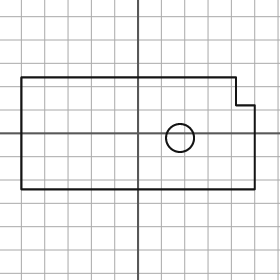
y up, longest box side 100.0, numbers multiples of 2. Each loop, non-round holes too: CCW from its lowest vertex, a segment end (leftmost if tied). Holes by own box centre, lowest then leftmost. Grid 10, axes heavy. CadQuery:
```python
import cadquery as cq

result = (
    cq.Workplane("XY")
    .moveTo(-50.0, -24.0)
    .lineTo(50.0, -24.0)
    .lineTo(50.0, 12.0)
    .lineTo(42.0, 12.0)
    .lineTo(42.0, 24.0)
    .lineTo(-50.0, 24.0)
    .close()
    .moveTo(18.0, -2.0)
    .circle(6.0)
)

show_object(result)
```